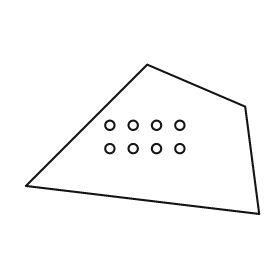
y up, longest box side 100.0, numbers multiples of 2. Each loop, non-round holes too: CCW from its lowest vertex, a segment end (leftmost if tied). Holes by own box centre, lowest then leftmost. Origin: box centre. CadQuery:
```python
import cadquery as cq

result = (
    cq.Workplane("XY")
    .moveTo(50.0, -32.0)
    .lineTo(44.0, 14.0)
    .lineTo(2.0, 32.0)
    .lineTo(-50.0, -20.0)
    .close()
    .moveTo(-14.0, -4.0)
    .circle(2.0)
    .moveTo(-4.0, -4.0)
    .circle(2.0)
    .moveTo(6.0, -4.0)
    .circle(2.0)
    .moveTo(16.0, -4.0)
    .circle(2.0)
    .moveTo(-14.0, 6.0)
    .circle(2.0)
    .moveTo(-4.0, 6.0)
    .circle(2.0)
    .moveTo(6.0, 6.0)
    .circle(2.0)
    .moveTo(16.0, 6.0)
    .circle(2.0)
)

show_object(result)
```